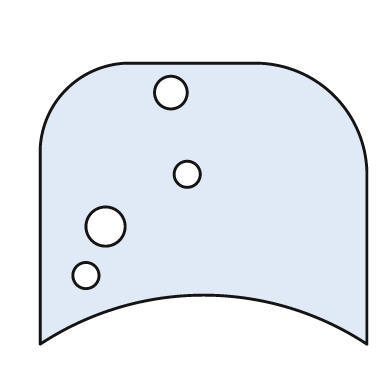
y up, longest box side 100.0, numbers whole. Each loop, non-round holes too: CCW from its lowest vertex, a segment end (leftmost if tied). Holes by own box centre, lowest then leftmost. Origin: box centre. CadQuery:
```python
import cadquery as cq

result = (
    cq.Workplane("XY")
    .moveTo(-50.0, -43.0)
    .threePointArc((0.0, -28.0), (50.0, -43.0))
    .lineTo(50.0, 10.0)
    .threePointArc((40.0, 33.0), (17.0, 43.0))
    .lineTo(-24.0, 43.0)
    .threePointArc((-42.0, 35.0), (-50.0, 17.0))
    .close()
    .moveTo(-36.0, -22.0)
    .circle(4.0)
    .moveTo(-30.0, -7.0)
    .circle(6.0)
    .moveTo(-5.0, 9.0)
    .circle(4.0)
    .moveTo(-10.0, 34.0)
    .circle(5.0)
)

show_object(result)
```